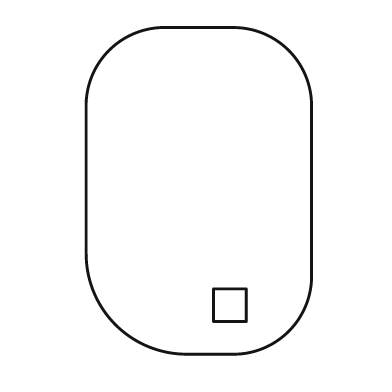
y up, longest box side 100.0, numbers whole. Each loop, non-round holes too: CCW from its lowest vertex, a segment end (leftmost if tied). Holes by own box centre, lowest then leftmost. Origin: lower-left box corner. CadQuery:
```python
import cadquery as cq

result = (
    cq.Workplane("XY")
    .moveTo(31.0, 0.0)
    .lineTo(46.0, 0.0)
    .threePointArc((62.0, 7.0), (69.0, 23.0))
    .lineTo(69.0, 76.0)
    .threePointArc((62.0, 93.0), (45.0, 100.0))
    .lineTo(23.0, 100.0)
    .threePointArc((7.0, 93.0), (0.0, 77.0))
    .lineTo(0.0, 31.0)
    .threePointArc((9.0, 9.0), (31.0, 0.0))
    .close()
    .moveTo(39.0, 10.0)
    .lineTo(49.0, 10.0)
    .lineTo(49.0, 20.0)
    .lineTo(39.0, 20.0)
    .close()
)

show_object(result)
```